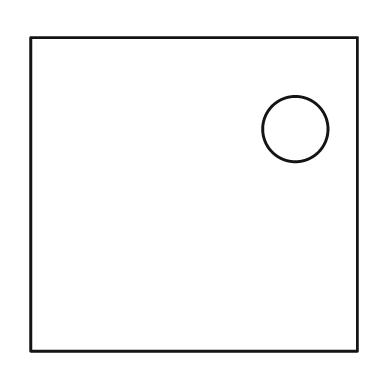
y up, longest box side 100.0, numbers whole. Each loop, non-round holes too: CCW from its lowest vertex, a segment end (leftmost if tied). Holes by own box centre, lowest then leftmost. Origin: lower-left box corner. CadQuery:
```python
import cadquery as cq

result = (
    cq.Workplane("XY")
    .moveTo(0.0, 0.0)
    .lineTo(100.0, 0.0)
    .lineTo(100.0, 96.0)
    .lineTo(0.0, 96.0)
    .close()
    .moveTo(81.0, 68.0)
    .circle(10.0)
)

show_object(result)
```